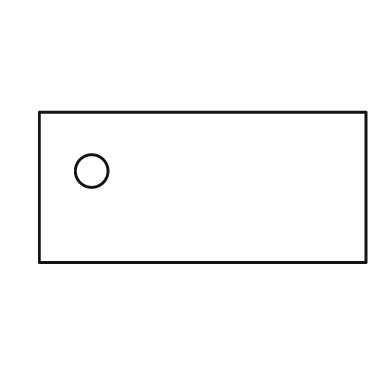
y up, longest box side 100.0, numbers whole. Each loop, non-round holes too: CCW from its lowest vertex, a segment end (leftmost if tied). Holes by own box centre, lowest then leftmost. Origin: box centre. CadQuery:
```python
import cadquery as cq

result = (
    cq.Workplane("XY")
    .moveTo(-50.0, -23.0)
    .lineTo(50.0, -23.0)
    .lineTo(50.0, 23.0)
    .lineTo(-50.0, 23.0)
    .close()
    .moveTo(-34.0, 5.0)
    .circle(5.0)
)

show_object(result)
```